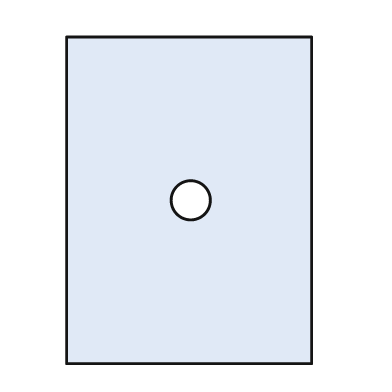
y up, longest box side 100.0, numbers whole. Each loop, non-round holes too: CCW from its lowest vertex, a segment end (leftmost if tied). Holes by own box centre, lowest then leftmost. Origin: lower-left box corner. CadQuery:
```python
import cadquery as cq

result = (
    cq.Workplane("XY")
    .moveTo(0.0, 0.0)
    .lineTo(75.0, 0.0)
    .lineTo(75.0, 100.0)
    .lineTo(0.0, 100.0)
    .close()
    .moveTo(38.0, 50.0)
    .circle(6.0)
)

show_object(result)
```